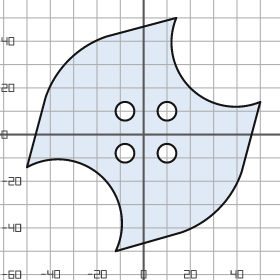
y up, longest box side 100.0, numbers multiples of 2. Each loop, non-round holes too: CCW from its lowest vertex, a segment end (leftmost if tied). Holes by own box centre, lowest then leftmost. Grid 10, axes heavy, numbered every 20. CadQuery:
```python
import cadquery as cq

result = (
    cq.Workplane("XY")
    .moveTo(-12.0, -50.0)
    .lineTo(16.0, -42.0)
    .threePointArc((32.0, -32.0), (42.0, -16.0))
    .lineTo(50.0, 14.0)
    .threePointArc((20.0, 20.0), (14.0, 50.0))
    .lineTo(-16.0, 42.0)
    .threePointArc((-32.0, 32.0), (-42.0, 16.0))
    .lineTo(-50.0, -14.0)
    .threePointArc((-18.0, -18.0), (-12.0, -50.0))
    .close()
    .moveTo(-8.0, -8.0)
    .circle(4.0)
    .moveTo(10.0, -8.0)
    .circle(4.0)
    .moveTo(-8.0, 10.0)
    .circle(4.0)
    .moveTo(10.0, 10.0)
    .circle(4.0)
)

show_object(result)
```